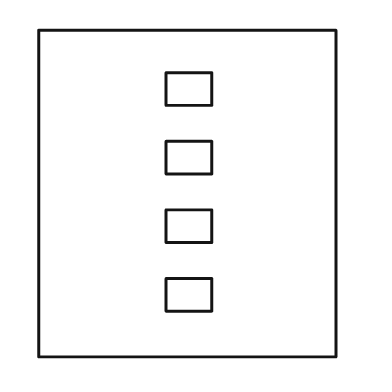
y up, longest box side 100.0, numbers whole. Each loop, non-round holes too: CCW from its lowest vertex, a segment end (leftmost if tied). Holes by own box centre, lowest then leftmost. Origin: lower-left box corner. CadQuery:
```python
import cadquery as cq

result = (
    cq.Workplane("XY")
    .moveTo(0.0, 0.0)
    .lineTo(91.0, 0.0)
    .lineTo(91.0, 100.0)
    .lineTo(0.0, 100.0)
    .close()
    .moveTo(39.0, 14.0)
    .lineTo(53.0, 14.0)
    .lineTo(53.0, 24.0)
    .lineTo(39.0, 24.0)
    .close()
    .moveTo(39.0, 35.0)
    .lineTo(53.0, 35.0)
    .lineTo(53.0, 45.0)
    .lineTo(39.0, 45.0)
    .close()
    .moveTo(39.0, 56.0)
    .lineTo(53.0, 56.0)
    .lineTo(53.0, 66.0)
    .lineTo(39.0, 66.0)
    .close()
    .moveTo(39.0, 77.0)
    .lineTo(53.0, 77.0)
    .lineTo(53.0, 87.0)
    .lineTo(39.0, 87.0)
    .close()
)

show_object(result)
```